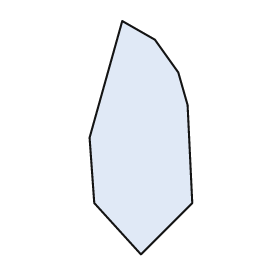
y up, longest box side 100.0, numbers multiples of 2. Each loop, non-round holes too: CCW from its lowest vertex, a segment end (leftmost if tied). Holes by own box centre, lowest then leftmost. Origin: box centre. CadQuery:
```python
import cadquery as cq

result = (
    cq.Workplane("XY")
    .moveTo(0.0, -50.0)
    .lineTo(22.0, -28.0)
    .lineTo(20.0, 14.0)
    .lineTo(16.0, 28.0)
    .lineTo(6.0, 42.0)
    .lineTo(-8.0, 50.0)
    .lineTo(-22.0, 0.0)
    .lineTo(-20.0, -28.0)
    .close()
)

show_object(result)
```